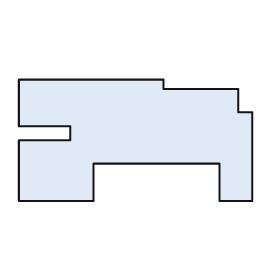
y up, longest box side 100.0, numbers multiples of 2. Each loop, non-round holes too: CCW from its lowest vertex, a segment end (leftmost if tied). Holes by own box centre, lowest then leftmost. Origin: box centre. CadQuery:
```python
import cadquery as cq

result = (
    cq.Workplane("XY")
    .moveTo(-50.0, -26.0)
    .lineTo(-18.0, -26.0)
    .lineTo(-18.0, -10.0)
    .lineTo(36.0, -10.0)
    .lineTo(36.0, -26.0)
    .lineTo(50.0, -26.0)
    .lineTo(50.0, 12.0)
    .lineTo(44.0, 12.0)
    .lineTo(44.0, 22.0)
    .lineTo(12.0, 22.0)
    .lineTo(12.0, 26.0)
    .lineTo(-50.0, 26.0)
    .lineTo(-50.0, 6.0)
    .lineTo(-28.0, 6.0)
    .lineTo(-28.0, 0.0)
    .lineTo(-50.0, 0.0)
    .close()
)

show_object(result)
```